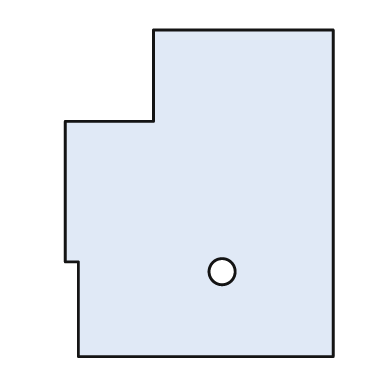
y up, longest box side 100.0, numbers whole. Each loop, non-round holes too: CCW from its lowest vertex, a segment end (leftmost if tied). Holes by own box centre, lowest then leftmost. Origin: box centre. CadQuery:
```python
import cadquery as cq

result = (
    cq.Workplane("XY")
    .moveTo(-37.0, -50.0)
    .lineTo(41.0, -50.0)
    .lineTo(41.0, 50.0)
    .lineTo(-14.0, 50.0)
    .lineTo(-14.0, 22.0)
    .lineTo(-41.0, 22.0)
    .lineTo(-41.0, -21.0)
    .lineTo(-37.0, -21.0)
    .close()
    .moveTo(7.0, -24.0)
    .circle(4.0)
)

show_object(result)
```